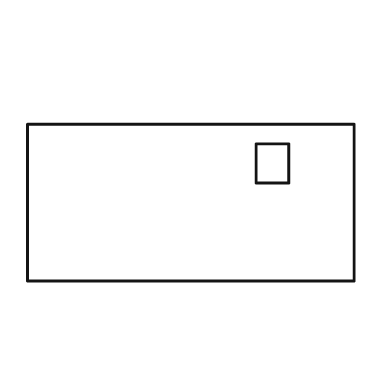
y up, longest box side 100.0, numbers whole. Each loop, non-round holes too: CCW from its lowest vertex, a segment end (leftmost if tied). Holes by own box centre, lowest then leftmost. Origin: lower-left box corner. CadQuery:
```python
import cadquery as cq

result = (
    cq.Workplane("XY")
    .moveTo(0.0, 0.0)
    .lineTo(100.0, 0.0)
    .lineTo(100.0, 48.0)
    .lineTo(0.0, 48.0)
    .close()
    .moveTo(70.0, 30.0)
    .lineTo(80.0, 30.0)
    .lineTo(80.0, 42.0)
    .lineTo(70.0, 42.0)
    .close()
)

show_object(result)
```